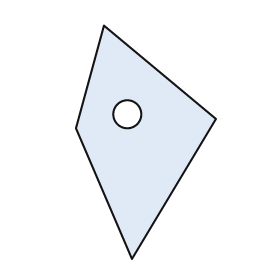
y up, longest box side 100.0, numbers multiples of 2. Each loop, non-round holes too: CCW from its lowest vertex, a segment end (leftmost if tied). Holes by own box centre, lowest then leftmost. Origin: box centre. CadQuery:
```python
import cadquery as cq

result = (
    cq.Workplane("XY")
    .moveTo(-6.0, -50.0)
    .lineTo(30.0, 10.0)
    .lineTo(-18.0, 50.0)
    .lineTo(-30.0, 6.0)
    .close()
    .moveTo(-8.0, 12.0)
    .circle(6.0)
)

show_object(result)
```